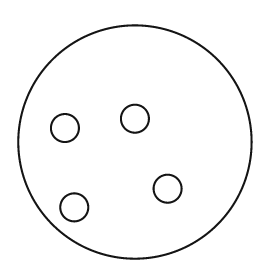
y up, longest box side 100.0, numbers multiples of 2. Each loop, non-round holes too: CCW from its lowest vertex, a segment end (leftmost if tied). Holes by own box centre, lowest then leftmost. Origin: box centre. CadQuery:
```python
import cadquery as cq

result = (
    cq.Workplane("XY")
    .moveTo(0.0, 0.0)
    .circle(50.0)
    .moveTo(-26.0, -28.0)
    .circle(6.0)
    .moveTo(14.0, -20.0)
    .circle(6.0)
    .moveTo(-30.0, 6.0)
    .circle(6.0)
    .moveTo(0.0, 10.0)
    .circle(6.0)
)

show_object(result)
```